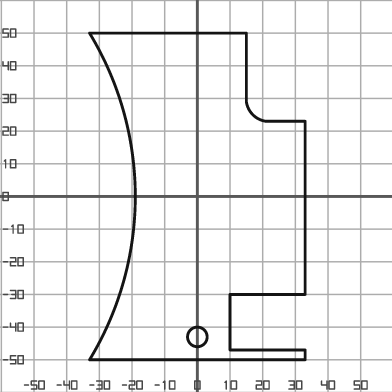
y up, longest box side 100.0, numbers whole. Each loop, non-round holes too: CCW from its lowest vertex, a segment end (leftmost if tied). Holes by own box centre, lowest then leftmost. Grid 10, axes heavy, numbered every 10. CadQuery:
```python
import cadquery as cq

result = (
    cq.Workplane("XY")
    .moveTo(-33.0, -50.0)
    .lineTo(33.0, -50.0)
    .lineTo(33.0, -47.0)
    .lineTo(10.0, -47.0)
    .lineTo(10.0, -30.0)
    .lineTo(33.0, -30.0)
    .lineTo(33.0, 23.0)
    .lineTo(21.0, 23.0)
    .threePointArc((17.0, 25.0), (15.0, 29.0))
    .lineTo(15.0, 50.0)
    .lineTo(-33.0, 50.0)
    .threePointArc((-19.0, 0.0), (-33.0, -50.0))
    .close()
    .moveTo(0.0, -43.0)
    .circle(3.0)
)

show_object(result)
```